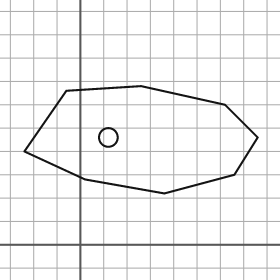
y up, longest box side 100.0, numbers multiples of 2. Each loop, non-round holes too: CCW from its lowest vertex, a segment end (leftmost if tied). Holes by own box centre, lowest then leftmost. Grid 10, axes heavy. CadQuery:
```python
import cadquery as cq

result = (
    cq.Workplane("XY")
    .moveTo(36.0, 22.0)
    .lineTo(66.0, 30.0)
    .lineTo(76.0, 46.0)
    .lineTo(62.0, 60.0)
    .lineTo(26.0, 68.0)
    .lineTo(-6.0, 66.0)
    .lineTo(-24.0, 40.0)
    .lineTo(2.0, 28.0)
    .close()
    .moveTo(12.0, 46.0)
    .circle(4.0)
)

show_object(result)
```